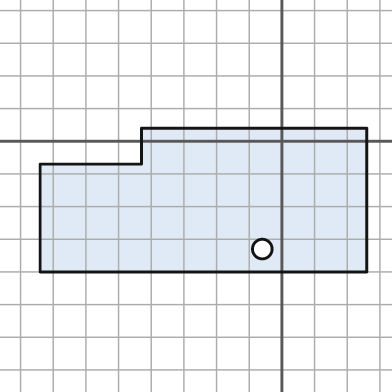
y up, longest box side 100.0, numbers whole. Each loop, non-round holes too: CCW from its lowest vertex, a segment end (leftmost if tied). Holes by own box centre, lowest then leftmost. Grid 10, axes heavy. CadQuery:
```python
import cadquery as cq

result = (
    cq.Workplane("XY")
    .moveTo(-74.0, -40.0)
    .lineTo(26.0, -40.0)
    .lineTo(26.0, 4.0)
    .lineTo(-43.0, 4.0)
    .lineTo(-43.0, -7.0)
    .lineTo(-74.0, -7.0)
    .close()
    .moveTo(-6.0, -33.0)
    .circle(3.0)
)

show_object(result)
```